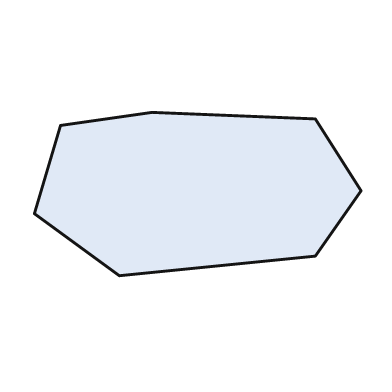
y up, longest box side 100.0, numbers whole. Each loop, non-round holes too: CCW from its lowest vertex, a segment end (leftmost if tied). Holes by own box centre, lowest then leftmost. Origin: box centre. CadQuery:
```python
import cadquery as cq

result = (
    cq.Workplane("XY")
    .moveTo(-24.0, -25.0)
    .lineTo(36.0, -19.0)
    .lineTo(50.0, 1.0)
    .lineTo(36.0, 23.0)
    .lineTo(-14.0, 25.0)
    .lineTo(-42.0, 21.0)
    .lineTo(-50.0, -6.0)
    .close()
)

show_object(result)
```